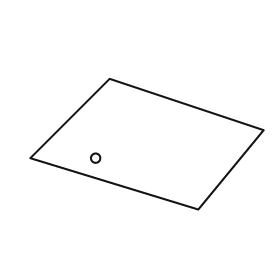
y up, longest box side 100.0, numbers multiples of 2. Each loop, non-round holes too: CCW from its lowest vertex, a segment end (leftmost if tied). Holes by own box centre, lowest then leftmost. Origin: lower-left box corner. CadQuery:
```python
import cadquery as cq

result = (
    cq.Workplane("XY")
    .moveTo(72.0, 0.0)
    .lineTo(100.0, 34.0)
    .lineTo(34.0, 56.0)
    .lineTo(0.0, 22.0)
    .close()
    .moveTo(28.0, 22.0)
    .circle(2.0)
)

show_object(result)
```